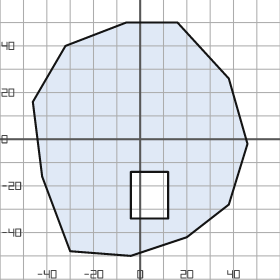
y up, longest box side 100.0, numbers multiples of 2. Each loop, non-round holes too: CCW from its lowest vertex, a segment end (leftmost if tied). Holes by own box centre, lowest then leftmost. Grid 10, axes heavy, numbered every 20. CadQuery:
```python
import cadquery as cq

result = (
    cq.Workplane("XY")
    .moveTo(-4.0, -50.0)
    .lineTo(20.0, -42.0)
    .lineTo(38.0, -28.0)
    .lineTo(46.0, -2.0)
    .lineTo(38.0, 26.0)
    .lineTo(16.0, 50.0)
    .lineTo(-6.0, 50.0)
    .lineTo(-32.0, 40.0)
    .lineTo(-46.0, 16.0)
    .lineTo(-42.0, -16.0)
    .lineTo(-30.0, -48.0)
    .close()
    .moveTo(-4.0, -34.0)
    .lineTo(12.0, -34.0)
    .lineTo(12.0, -14.0)
    .lineTo(-4.0, -14.0)
    .close()
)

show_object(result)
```